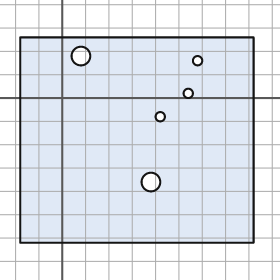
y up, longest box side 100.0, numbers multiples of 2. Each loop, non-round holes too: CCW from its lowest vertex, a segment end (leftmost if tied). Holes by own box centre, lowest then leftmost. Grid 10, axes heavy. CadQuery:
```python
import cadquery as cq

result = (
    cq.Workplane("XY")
    .moveTo(-18.0, -62.0)
    .lineTo(82.0, -62.0)
    .lineTo(82.0, 26.0)
    .lineTo(-18.0, 26.0)
    .close()
    .moveTo(38.0, -36.0)
    .circle(4.0)
    .moveTo(42.0, -8.0)
    .circle(2.0)
    .moveTo(54.0, 2.0)
    .circle(2.0)
    .moveTo(58.0, 16.0)
    .circle(2.0)
    .moveTo(8.0, 18.0)
    .circle(4.0)
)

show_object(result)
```